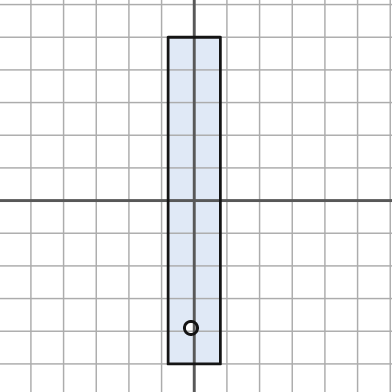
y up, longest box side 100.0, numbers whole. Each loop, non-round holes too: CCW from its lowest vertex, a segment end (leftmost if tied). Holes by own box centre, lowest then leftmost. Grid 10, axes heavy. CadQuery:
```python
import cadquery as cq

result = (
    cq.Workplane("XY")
    .moveTo(-8.0, -50.0)
    .lineTo(8.0, -50.0)
    .lineTo(8.0, 50.0)
    .lineTo(-8.0, 50.0)
    .close()
    .moveTo(-1.0, -39.0)
    .circle(2.0)
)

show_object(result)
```